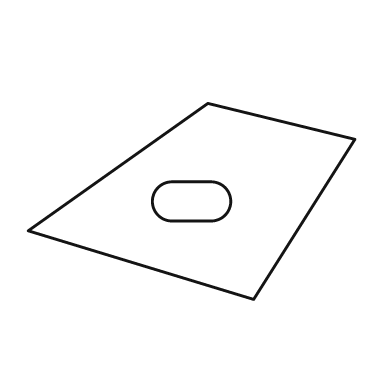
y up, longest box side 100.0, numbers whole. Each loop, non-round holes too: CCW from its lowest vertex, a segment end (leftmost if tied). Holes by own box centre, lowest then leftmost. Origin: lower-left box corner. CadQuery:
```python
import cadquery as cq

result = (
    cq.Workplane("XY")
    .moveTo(69.0, 0.0)
    .lineTo(100.0, 49.0)
    .lineTo(55.0, 60.0)
    .lineTo(0.0, 21.0)
    .close()
    .moveTo(44.0, 24.0)
    .lineTo(56.0, 24.0)
    .threePointArc((62.0, 30.0), (56.0, 36.0))
    .lineTo(44.0, 36.0)
    .threePointArc((38.0, 30.0), (44.0, 24.0))
    .close()
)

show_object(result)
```